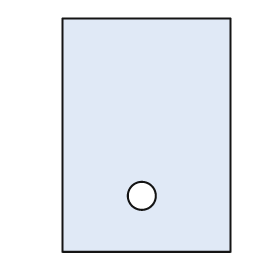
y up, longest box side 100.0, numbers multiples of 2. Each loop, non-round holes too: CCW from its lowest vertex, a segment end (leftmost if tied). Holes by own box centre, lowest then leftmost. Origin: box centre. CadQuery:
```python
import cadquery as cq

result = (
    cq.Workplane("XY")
    .moveTo(-36.0, -50.0)
    .lineTo(36.0, -50.0)
    .lineTo(36.0, 50.0)
    .lineTo(-36.0, 50.0)
    .close()
    .moveTo(-2.0, -26.0)
    .circle(6.0)
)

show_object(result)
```